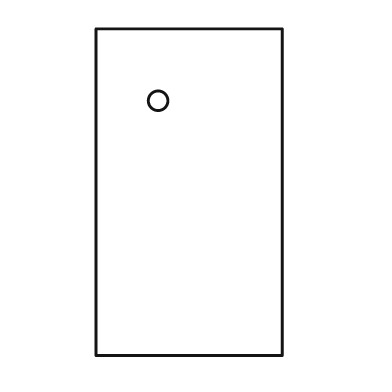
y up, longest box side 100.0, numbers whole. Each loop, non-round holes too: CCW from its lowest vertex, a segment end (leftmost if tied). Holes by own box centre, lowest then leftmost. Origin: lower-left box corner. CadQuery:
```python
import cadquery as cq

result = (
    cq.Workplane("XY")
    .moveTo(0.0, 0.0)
    .lineTo(57.0, 0.0)
    .lineTo(57.0, 100.0)
    .lineTo(0.0, 100.0)
    .close()
    .moveTo(19.0, 78.0)
    .circle(3.0)
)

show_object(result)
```